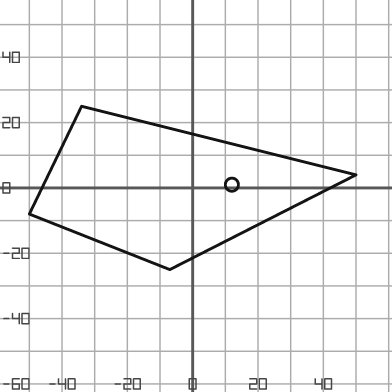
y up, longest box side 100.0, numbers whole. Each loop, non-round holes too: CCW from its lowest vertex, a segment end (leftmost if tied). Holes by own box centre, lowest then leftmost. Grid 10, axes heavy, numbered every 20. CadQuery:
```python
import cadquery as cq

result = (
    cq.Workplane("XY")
    .moveTo(-7.0, -25.0)
    .lineTo(50.0, 4.0)
    .lineTo(-34.0, 25.0)
    .lineTo(-50.0, -8.0)
    .close()
    .moveTo(12.0, 1.0)
    .circle(2.0)
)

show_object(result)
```